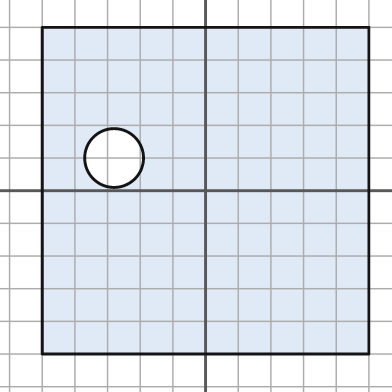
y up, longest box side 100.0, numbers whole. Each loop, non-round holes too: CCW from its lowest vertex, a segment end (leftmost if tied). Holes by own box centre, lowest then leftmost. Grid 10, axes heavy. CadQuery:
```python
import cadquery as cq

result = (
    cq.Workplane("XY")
    .moveTo(-50.0, -50.0)
    .lineTo(50.0, -50.0)
    .lineTo(50.0, 50.0)
    .lineTo(-50.0, 50.0)
    .close()
    .moveTo(-28.0, 10.0)
    .circle(9.0)
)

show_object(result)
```